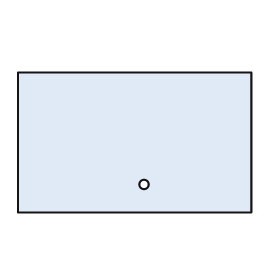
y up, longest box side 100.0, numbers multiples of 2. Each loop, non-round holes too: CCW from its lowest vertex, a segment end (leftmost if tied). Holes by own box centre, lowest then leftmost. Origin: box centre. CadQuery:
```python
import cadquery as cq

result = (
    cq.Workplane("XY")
    .moveTo(-50.0, -30.0)
    .lineTo(50.0, -30.0)
    .lineTo(50.0, 30.0)
    .lineTo(-50.0, 30.0)
    .close()
    .moveTo(4.0, -18.0)
    .circle(2.0)
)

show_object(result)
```